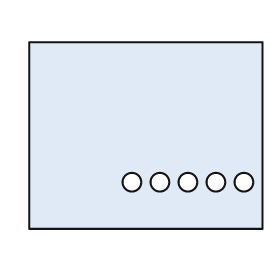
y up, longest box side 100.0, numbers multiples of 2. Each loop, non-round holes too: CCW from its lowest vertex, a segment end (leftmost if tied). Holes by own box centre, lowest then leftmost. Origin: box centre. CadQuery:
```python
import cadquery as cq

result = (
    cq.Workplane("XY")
    .moveTo(-50.0, -40.0)
    .lineTo(50.0, -40.0)
    .lineTo(50.0, 40.0)
    .lineTo(-50.0, 40.0)
    .close()
    .moveTo(-6.0, -20.0)
    .circle(4.0)
    .moveTo(6.0, -20.0)
    .circle(4.0)
    .moveTo(18.0, -20.0)
    .circle(4.0)
    .moveTo(30.0, -20.0)
    .circle(4.0)
    .moveTo(42.0, -20.0)
    .circle(4.0)
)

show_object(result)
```